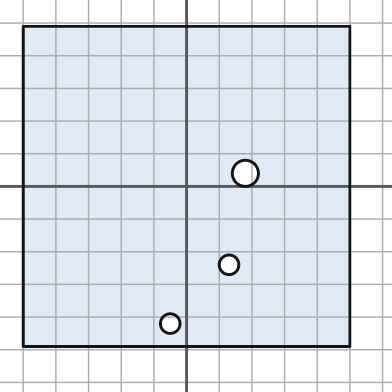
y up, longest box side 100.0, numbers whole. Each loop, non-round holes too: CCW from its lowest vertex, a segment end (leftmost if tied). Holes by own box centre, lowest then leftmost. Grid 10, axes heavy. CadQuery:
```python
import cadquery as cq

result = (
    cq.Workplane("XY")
    .moveTo(-50.0, -49.0)
    .lineTo(50.0, -49.0)
    .lineTo(50.0, 49.0)
    .lineTo(-50.0, 49.0)
    .close()
    .moveTo(-5.0, -42.0)
    .circle(3.0)
    .moveTo(13.0, -24.0)
    .circle(3.0)
    .moveTo(18.0, 4.0)
    .circle(4.0)
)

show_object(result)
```